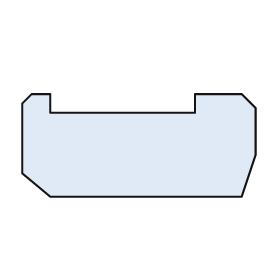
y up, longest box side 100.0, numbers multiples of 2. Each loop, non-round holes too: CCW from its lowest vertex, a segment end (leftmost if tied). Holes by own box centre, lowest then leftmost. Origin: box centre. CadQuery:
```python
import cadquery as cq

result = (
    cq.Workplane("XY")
    .moveTo(-38.0, -22.0)
    .lineTo(44.0, -22.0)
    .lineTo(50.0, -4.0)
    .lineTo(50.0, 16.0)
    .lineTo(44.0, 22.0)
    .lineTo(24.0, 22.0)
    .lineTo(24.0, 14.0)
    .lineTo(-38.0, 14.0)
    .lineTo(-38.0, 22.0)
    .lineTo(-46.0, 22.0)
    .lineTo(-50.0, 18.0)
    .lineTo(-50.0, -12.0)
    .close()
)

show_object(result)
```